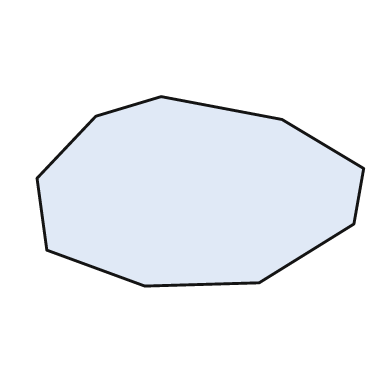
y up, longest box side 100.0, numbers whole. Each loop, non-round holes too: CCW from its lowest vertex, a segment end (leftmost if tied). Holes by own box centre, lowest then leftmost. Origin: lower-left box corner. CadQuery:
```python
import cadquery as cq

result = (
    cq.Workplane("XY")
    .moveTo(33.0, 0.0)
    .lineTo(68.0, 1.0)
    .lineTo(97.0, 19.0)
    .lineTo(100.0, 36.0)
    .lineTo(75.0, 51.0)
    .lineTo(38.0, 58.0)
    .lineTo(18.0, 52.0)
    .lineTo(0.0, 33.0)
    .lineTo(3.0, 11.0)
    .close()
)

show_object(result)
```